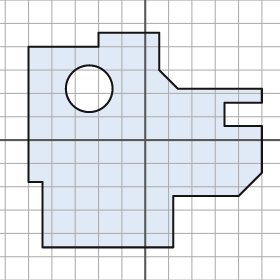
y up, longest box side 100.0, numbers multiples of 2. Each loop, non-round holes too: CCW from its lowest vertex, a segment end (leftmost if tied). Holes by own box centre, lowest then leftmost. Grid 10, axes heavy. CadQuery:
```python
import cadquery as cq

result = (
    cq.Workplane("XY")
    .moveTo(-44.0, -46.0)
    .lineTo(12.0, -46.0)
    .lineTo(12.0, -24.0)
    .lineTo(40.0, -24.0)
    .lineTo(50.0, -14.0)
    .lineTo(50.0, 6.0)
    .lineTo(34.0, 6.0)
    .lineTo(34.0, 16.0)
    .lineTo(50.0, 16.0)
    .lineTo(50.0, 22.0)
    .lineTo(14.0, 22.0)
    .lineTo(6.0, 30.0)
    .lineTo(6.0, 46.0)
    .lineTo(-20.0, 46.0)
    .lineTo(-20.0, 40.0)
    .lineTo(-50.0, 40.0)
    .lineTo(-50.0, -18.0)
    .lineTo(-44.0, -18.0)
    .close()
    .moveTo(-24.0, 22.0)
    .circle(10.0)
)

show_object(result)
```